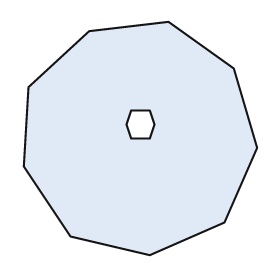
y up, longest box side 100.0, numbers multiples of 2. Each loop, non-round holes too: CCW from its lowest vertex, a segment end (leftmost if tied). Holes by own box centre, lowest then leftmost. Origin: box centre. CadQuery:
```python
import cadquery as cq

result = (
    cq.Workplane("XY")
    .moveTo(4.0, -50.0)
    .lineTo(36.0, -36.0)
    .lineTo(50.0, -4.0)
    .lineTo(40.0, 30.0)
    .lineTo(12.0, 50.0)
    .lineTo(-22.0, 46.0)
    .lineTo(-48.0, 22.0)
    .lineTo(-50.0, -12.0)
    .lineTo(-30.0, -42.0)
    .close()
    .moveTo(-4.0, 0.0)
    .lineTo(4.0, 0.0)
    .lineTo(6.0, 6.0)
    .lineTo(4.0, 12.0)
    .lineTo(-4.0, 12.0)
    .lineTo(-6.0, 6.0)
    .close()
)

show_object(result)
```